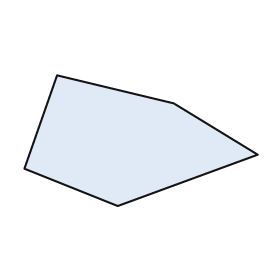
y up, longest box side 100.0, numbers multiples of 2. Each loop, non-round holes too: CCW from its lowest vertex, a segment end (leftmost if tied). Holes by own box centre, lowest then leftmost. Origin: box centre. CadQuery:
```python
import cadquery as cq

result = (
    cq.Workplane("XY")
    .moveTo(-10.0, -28.0)
    .lineTo(50.0, -6.0)
    .lineTo(14.0, 16.0)
    .lineTo(-36.0, 28.0)
    .lineTo(-50.0, -12.0)
    .close()
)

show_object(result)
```